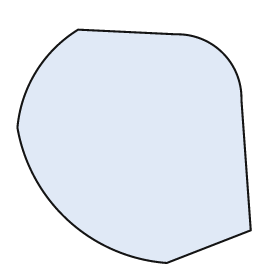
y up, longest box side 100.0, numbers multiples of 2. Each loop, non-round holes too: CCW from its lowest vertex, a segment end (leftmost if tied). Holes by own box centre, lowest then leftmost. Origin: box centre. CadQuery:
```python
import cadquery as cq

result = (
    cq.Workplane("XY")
    .moveTo(14.0, -50.0)
    .lineTo(50.0, -36.0)
    .lineTo(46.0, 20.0)
    .threePointArc((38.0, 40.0), (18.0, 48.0))
    .lineTo(-24.0, 50.0)
    .threePointArc((-42.0, 32.0), (-50.0, 8.0))
    .threePointArc((-28.0, -32.0), (14.0, -50.0))
    .close()
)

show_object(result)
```